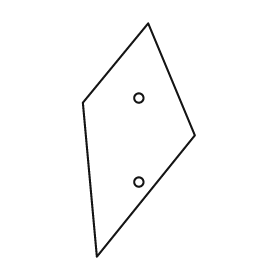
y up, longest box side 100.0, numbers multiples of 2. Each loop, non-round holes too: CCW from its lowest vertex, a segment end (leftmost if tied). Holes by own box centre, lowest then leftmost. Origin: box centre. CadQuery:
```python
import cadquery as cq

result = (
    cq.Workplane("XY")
    .moveTo(-18.0, -50.0)
    .lineTo(24.0, 2.0)
    .lineTo(4.0, 50.0)
    .lineTo(-24.0, 16.0)
    .close()
    .moveTo(0.0, -18.0)
    .circle(2.0)
    .moveTo(0.0, 18.0)
    .circle(2.0)
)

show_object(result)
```